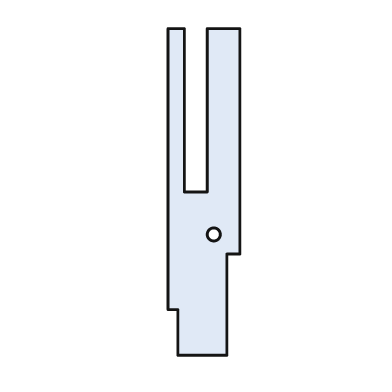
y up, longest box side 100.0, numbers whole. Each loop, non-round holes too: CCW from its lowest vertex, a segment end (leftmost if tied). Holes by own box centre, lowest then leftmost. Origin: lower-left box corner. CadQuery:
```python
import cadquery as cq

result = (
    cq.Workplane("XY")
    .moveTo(3.0, 0.0)
    .lineTo(18.0, 0.0)
    .lineTo(18.0, 31.0)
    .lineTo(22.0, 31.0)
    .lineTo(22.0, 100.0)
    .lineTo(12.0, 100.0)
    .lineTo(12.0, 50.0)
    .lineTo(5.0, 50.0)
    .lineTo(5.0, 100.0)
    .lineTo(0.0, 100.0)
    .lineTo(0.0, 14.0)
    .lineTo(3.0, 14.0)
    .close()
    .moveTo(14.0, 37.0)
    .circle(2.0)
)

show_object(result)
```